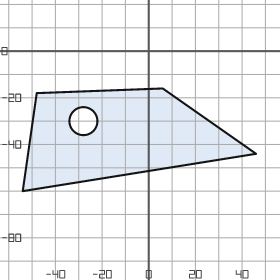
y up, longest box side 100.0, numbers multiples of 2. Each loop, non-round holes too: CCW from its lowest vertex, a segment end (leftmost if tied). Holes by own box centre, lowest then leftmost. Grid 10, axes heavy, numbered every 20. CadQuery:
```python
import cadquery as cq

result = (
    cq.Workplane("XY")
    .moveTo(-54.0, -60.0)
    .lineTo(46.0, -44.0)
    .lineTo(6.0, -16.0)
    .lineTo(-48.0, -18.0)
    .close()
    .moveTo(-28.0, -30.0)
    .circle(6.0)
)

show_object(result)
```